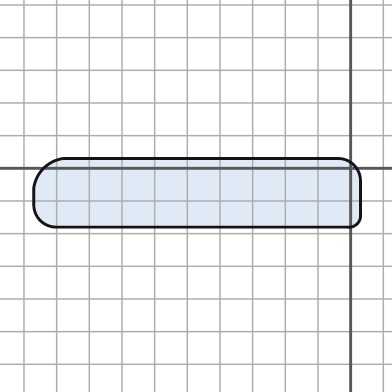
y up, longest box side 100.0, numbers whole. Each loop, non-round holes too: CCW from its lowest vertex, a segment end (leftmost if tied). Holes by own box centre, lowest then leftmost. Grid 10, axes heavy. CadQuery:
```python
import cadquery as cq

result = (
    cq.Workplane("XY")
    .moveTo(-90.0, -18.0)
    .lineTo(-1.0, -18.0)
    .threePointArc((2.0, -17.0), (3.0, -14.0))
    .lineTo(3.0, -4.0)
    .threePointArc((1.0, 1.0), (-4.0, 3.0))
    .lineTo(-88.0, 3.0)
    .threePointArc((-94.0, 0.0), (-97.0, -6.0))
    .lineTo(-97.0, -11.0)
    .threePointArc((-95.0, -16.0), (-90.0, -18.0))
    .close()
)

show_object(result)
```